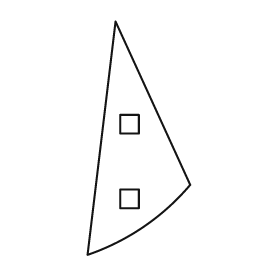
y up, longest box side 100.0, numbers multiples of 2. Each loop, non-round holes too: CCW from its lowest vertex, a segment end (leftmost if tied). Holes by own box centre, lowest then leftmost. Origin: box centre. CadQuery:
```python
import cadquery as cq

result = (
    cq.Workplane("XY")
    .moveTo(-22.0, -50.0)
    .threePointArc((2.0, -38.0), (22.0, -20.0))
    .lineTo(-10.0, 50.0)
    .close()
    .moveTo(-8.0, -30.0)
    .lineTo(0.0, -30.0)
    .lineTo(0.0, -22.0)
    .lineTo(-8.0, -22.0)
    .close()
    .moveTo(-8.0, 2.0)
    .lineTo(0.0, 2.0)
    .lineTo(0.0, 10.0)
    .lineTo(-8.0, 10.0)
    .close()
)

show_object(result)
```